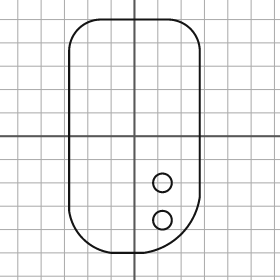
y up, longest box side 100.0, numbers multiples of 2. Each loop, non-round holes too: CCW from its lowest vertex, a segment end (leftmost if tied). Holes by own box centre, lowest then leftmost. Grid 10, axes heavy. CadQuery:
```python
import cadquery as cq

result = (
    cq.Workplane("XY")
    .moveTo(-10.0, -50.0)
    .lineTo(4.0, -50.0)
    .threePointArc((20.0, -42.0), (28.0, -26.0))
    .lineTo(28.0, 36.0)
    .threePointArc((24.0, 46.0), (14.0, 50.0))
    .lineTo(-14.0, 50.0)
    .threePointArc((-24.0, 46.0), (-28.0, 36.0))
    .lineTo(-28.0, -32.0)
    .threePointArc((-22.0, -44.0), (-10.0, -50.0))
    .close()
    .moveTo(12.0, -36.0)
    .circle(4.0)
    .moveTo(12.0, -20.0)
    .circle(4.0)
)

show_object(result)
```